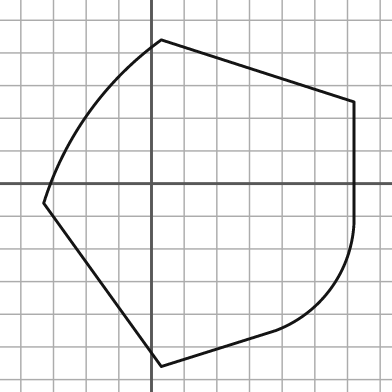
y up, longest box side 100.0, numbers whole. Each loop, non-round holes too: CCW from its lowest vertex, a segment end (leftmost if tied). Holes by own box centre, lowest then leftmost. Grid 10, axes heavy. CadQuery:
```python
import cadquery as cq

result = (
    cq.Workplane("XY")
    .moveTo(3.0, -56.0)
    .lineTo(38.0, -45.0)
    .threePointArc((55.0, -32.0), (62.0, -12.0))
    .lineTo(62.0, 25.0)
    .lineTo(3.0, 44.0)
    .threePointArc((-19.0, 22.0), (-33.0, -6.0))
    .close()
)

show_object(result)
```